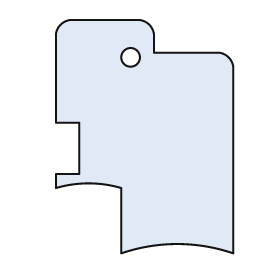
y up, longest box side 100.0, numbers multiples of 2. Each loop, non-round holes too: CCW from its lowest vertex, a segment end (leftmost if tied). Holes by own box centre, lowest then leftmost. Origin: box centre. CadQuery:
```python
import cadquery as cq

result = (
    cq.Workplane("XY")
    .moveTo(-10.0, -50.0)
    .threePointArc((14.0, -46.0), (38.0, -50.0))
    .lineTo(38.0, 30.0)
    .threePointArc((36.0, 34.0), (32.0, 36.0))
    .lineTo(4.0, 36.0)
    .lineTo(4.0, 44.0)
    .threePointArc((2.0, 48.0), (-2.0, 50.0))
    .lineTo(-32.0, 50.0)
    .threePointArc((-36.0, 48.0), (-38.0, 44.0))
    .lineTo(-38.0, 6.0)
    .lineTo(-28.0, 6.0)
    .lineTo(-28.0, -16.0)
    .lineTo(-38.0, -16.0)
    .lineTo(-38.0, -22.0)
    .threePointArc((-24.0, -20.0), (-10.0, -22.0))
    .close()
    .moveTo(-6.0, 34.0)
    .circle(4.0)
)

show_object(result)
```